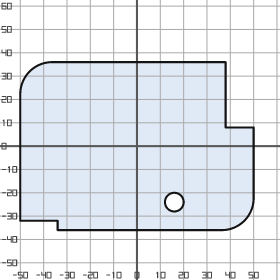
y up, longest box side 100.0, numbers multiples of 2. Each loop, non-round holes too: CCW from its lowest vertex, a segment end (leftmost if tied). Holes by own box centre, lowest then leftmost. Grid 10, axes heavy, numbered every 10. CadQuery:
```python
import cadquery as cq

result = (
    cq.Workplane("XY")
    .moveTo(-34.0, -36.0)
    .lineTo(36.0, -36.0)
    .threePointArc((46.0, -32.0), (50.0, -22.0))
    .lineTo(50.0, 8.0)
    .lineTo(38.0, 8.0)
    .lineTo(38.0, 36.0)
    .lineTo(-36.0, 36.0)
    .threePointArc((-46.0, 32.0), (-50.0, 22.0))
    .lineTo(-50.0, -32.0)
    .lineTo(-34.0, -32.0)
    .close()
    .moveTo(16.0, -24.0)
    .circle(4.0)
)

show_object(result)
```